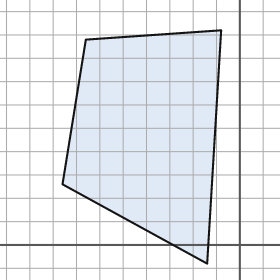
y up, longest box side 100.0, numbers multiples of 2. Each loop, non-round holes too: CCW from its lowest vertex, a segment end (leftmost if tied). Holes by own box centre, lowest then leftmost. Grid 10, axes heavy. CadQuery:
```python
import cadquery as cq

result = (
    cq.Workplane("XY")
    .moveTo(-14.0, -8.0)
    .lineTo(-8.0, 92.0)
    .lineTo(-66.0, 88.0)
    .lineTo(-76.0, 26.0)
    .close()
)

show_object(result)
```